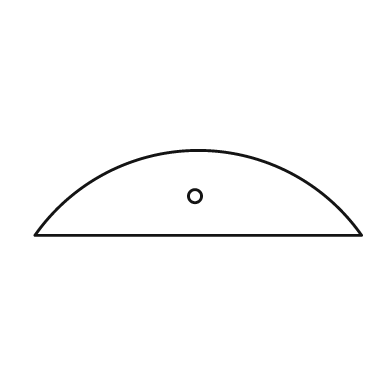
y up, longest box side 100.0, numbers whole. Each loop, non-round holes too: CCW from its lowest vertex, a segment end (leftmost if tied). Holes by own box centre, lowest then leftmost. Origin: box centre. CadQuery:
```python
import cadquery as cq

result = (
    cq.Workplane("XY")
    .moveTo(-50.0, -13.0)
    .lineTo(50.0, -13.0)
    .threePointArc((0.0, 13.0), (-50.0, -13.0))
    .close()
    .moveTo(-1.0, -1.0)
    .circle(2.0)
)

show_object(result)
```